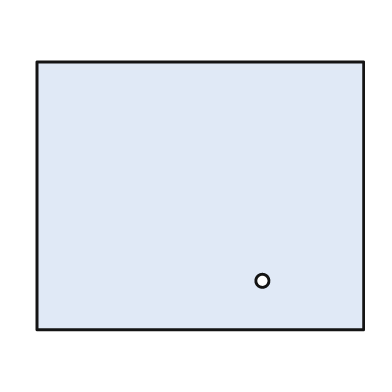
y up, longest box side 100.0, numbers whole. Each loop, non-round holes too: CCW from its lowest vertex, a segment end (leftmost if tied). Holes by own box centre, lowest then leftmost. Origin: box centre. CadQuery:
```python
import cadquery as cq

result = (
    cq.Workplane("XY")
    .moveTo(-50.0, -41.0)
    .lineTo(50.0, -41.0)
    .lineTo(50.0, 41.0)
    .lineTo(-50.0, 41.0)
    .close()
    .moveTo(19.0, -26.0)
    .circle(2.0)
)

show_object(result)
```